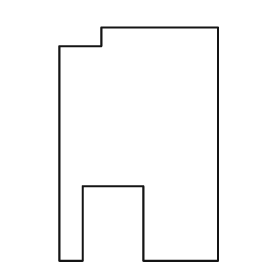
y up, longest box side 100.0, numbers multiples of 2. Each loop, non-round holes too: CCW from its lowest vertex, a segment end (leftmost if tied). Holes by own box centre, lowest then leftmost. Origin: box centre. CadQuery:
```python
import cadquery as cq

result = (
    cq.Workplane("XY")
    .moveTo(-34.0, -50.0)
    .lineTo(-24.0, -50.0)
    .lineTo(-24.0, -18.0)
    .lineTo(2.0, -18.0)
    .lineTo(2.0, -50.0)
    .lineTo(34.0, -50.0)
    .lineTo(34.0, 50.0)
    .lineTo(-16.0, 50.0)
    .lineTo(-16.0, 42.0)
    .lineTo(-34.0, 42.0)
    .close()
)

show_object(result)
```